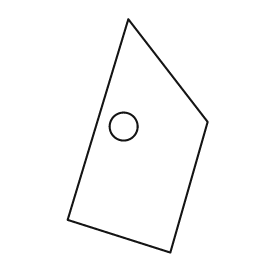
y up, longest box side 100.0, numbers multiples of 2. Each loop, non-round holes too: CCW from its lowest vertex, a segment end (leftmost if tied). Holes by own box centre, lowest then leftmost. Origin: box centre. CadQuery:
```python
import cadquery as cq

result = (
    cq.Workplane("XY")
    .moveTo(14.0, -50.0)
    .lineTo(30.0, 6.0)
    .lineTo(-4.0, 50.0)
    .lineTo(-30.0, -36.0)
    .close()
    .moveTo(-6.0, 4.0)
    .circle(6.0)
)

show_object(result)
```